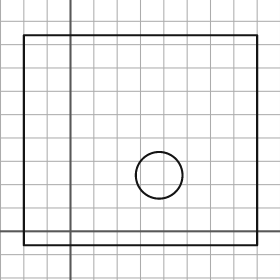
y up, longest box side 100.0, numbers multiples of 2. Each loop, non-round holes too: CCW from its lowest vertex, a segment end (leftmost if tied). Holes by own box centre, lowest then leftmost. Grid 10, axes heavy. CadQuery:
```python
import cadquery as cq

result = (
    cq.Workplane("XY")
    .moveTo(-20.0, -6.0)
    .lineTo(80.0, -6.0)
    .lineTo(80.0, 84.0)
    .lineTo(-20.0, 84.0)
    .close()
    .moveTo(38.0, 24.0)
    .circle(10.0)
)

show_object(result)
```